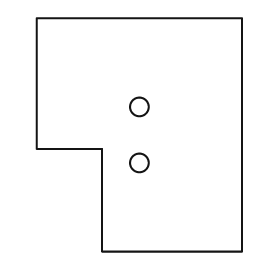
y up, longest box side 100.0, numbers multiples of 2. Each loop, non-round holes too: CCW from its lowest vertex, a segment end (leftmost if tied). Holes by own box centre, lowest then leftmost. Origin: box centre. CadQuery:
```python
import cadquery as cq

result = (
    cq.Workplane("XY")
    .moveTo(-16.0, -50.0)
    .lineTo(44.0, -50.0)
    .lineTo(44.0, 50.0)
    .lineTo(-44.0, 50.0)
    .lineTo(-44.0, -6.0)
    .lineTo(-16.0, -6.0)
    .close()
    .moveTo(0.0, -12.0)
    .circle(4.0)
    .moveTo(0.0, 12.0)
    .circle(4.0)
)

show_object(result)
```